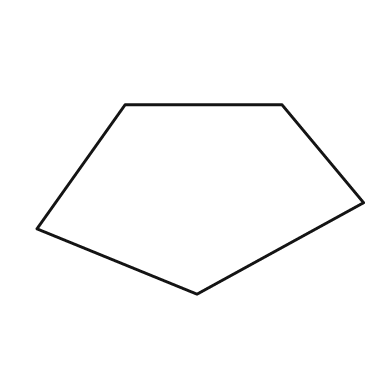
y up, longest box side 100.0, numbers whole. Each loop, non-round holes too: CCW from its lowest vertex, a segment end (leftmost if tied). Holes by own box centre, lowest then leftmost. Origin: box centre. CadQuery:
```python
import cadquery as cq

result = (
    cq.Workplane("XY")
    .moveTo(-1.0, -29.0)
    .lineTo(50.0, -1.0)
    .lineTo(25.0, 29.0)
    .lineTo(-23.0, 29.0)
    .lineTo(-50.0, -9.0)
    .close()
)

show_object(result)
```